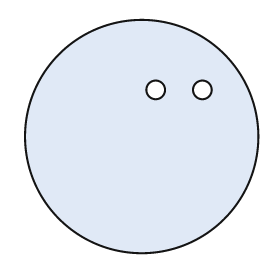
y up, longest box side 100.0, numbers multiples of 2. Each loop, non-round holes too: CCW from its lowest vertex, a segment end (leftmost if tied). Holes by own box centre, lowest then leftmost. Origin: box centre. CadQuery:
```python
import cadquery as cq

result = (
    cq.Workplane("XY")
    .moveTo(0.0, 0.0)
    .circle(50.0)
    .moveTo(6.0, 20.0)
    .circle(4.0)
    .moveTo(26.0, 20.0)
    .circle(4.0)
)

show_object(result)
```